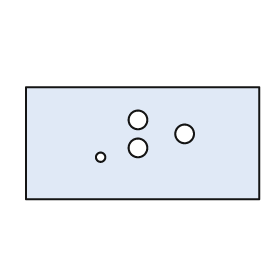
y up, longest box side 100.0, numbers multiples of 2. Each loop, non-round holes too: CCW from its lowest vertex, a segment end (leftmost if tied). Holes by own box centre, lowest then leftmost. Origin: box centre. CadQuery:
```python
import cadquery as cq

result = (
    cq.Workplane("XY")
    .moveTo(-50.0, -24.0)
    .lineTo(50.0, -24.0)
    .lineTo(50.0, 24.0)
    .lineTo(-50.0, 24.0)
    .close()
    .moveTo(-18.0, -6.0)
    .circle(2.0)
    .moveTo(-2.0, -2.0)
    .circle(4.0)
    .moveTo(18.0, 4.0)
    .circle(4.0)
    .moveTo(-2.0, 10.0)
    .circle(4.0)
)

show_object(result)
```